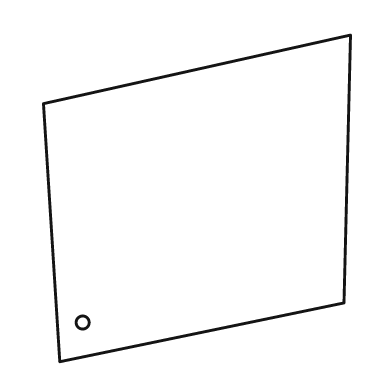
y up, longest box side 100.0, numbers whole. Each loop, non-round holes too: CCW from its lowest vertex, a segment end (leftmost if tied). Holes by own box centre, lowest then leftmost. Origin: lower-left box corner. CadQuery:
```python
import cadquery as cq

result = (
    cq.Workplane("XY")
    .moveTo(5.0, 0.0)
    .lineTo(92.0, 18.0)
    .lineTo(94.0, 100.0)
    .lineTo(0.0, 79.0)
    .close()
    .moveTo(12.0, 12.0)
    .circle(2.0)
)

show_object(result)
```